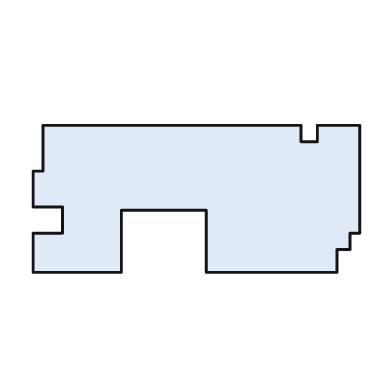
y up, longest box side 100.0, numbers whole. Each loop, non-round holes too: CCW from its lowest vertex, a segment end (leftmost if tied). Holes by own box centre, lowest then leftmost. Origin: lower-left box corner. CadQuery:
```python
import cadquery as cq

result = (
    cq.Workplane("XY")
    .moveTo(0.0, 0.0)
    .lineTo(27.0, 0.0)
    .lineTo(27.0, 19.0)
    .lineTo(53.0, 19.0)
    .lineTo(53.0, 0.0)
    .lineTo(93.0, 0.0)
    .lineTo(93.0, 7.0)
    .lineTo(97.0, 7.0)
    .lineTo(97.0, 12.0)
    .lineTo(100.0, 12.0)
    .lineTo(100.0, 45.0)
    .lineTo(87.0, 45.0)
    .lineTo(87.0, 40.0)
    .lineTo(82.0, 40.0)
    .lineTo(82.0, 45.0)
    .lineTo(3.0, 45.0)
    .lineTo(3.0, 31.0)
    .lineTo(0.0, 31.0)
    .lineTo(0.0, 20.0)
    .lineTo(9.0, 20.0)
    .lineTo(9.0, 12.0)
    .lineTo(0.0, 12.0)
    .close()
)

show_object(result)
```